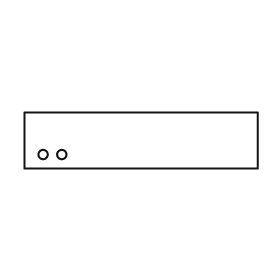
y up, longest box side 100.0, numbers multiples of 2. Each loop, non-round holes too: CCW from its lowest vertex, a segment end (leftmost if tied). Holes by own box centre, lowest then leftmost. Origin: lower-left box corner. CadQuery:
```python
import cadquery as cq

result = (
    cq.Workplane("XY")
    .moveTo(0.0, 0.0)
    .lineTo(100.0, 0.0)
    .lineTo(100.0, 24.0)
    .lineTo(0.0, 24.0)
    .close()
    .moveTo(8.0, 6.0)
    .circle(2.0)
    .moveTo(16.0, 6.0)
    .circle(2.0)
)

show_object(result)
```